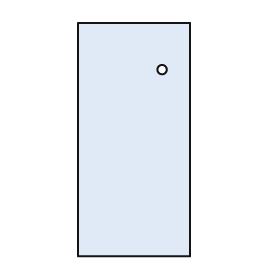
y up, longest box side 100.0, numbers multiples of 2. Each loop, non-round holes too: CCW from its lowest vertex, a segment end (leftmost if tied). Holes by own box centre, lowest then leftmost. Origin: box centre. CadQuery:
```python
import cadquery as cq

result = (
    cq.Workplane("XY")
    .moveTo(-24.0, -50.0)
    .lineTo(24.0, -50.0)
    .lineTo(24.0, 50.0)
    .lineTo(-24.0, 50.0)
    .close()
    .moveTo(12.0, 30.0)
    .circle(2.0)
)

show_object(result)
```